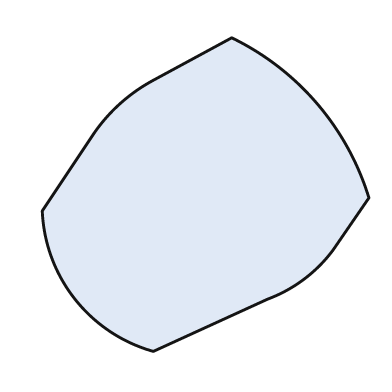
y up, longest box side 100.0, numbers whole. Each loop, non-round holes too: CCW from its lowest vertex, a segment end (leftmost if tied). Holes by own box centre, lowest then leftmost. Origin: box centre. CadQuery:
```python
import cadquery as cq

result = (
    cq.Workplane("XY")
    .moveTo(-16.0, -48.0)
    .lineTo(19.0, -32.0)
    .threePointArc((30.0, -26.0), (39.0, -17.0))
    .lineTo(50.0, -1.0)
    .threePointArc((34.0, 28.0), (8.0, 48.0))
    .lineTo(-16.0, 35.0)
    .threePointArc((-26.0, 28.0), (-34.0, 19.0))
    .lineTo(-50.0, -5.0)
    .threePointArc((-40.0, -32.0), (-16.0, -48.0))
    .close()
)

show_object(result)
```